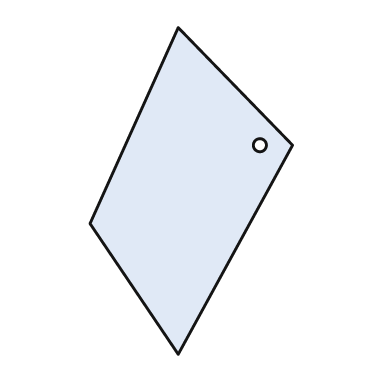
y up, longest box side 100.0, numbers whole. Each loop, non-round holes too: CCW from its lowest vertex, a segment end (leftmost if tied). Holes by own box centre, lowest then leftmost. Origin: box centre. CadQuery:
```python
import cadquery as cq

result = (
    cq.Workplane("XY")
    .moveTo(-4.0, -50.0)
    .lineTo(31.0, 14.0)
    .lineTo(-4.0, 50.0)
    .lineTo(-31.0, -10.0)
    .close()
    .moveTo(21.0, 14.0)
    .circle(2.0)
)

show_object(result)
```